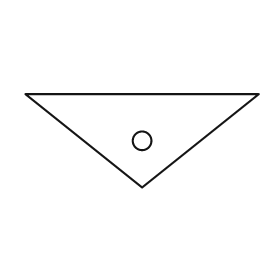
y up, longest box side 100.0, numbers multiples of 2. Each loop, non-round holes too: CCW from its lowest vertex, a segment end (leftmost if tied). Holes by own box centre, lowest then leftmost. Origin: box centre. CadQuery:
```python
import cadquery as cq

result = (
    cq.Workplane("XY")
    .moveTo(0.0, -20.0)
    .lineTo(50.0, 20.0)
    .lineTo(-50.0, 20.0)
    .close()
    .moveTo(0.0, 0.0)
    .circle(4.0)
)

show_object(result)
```